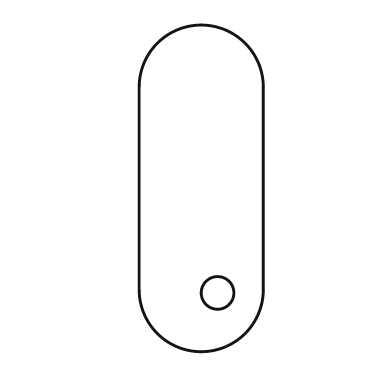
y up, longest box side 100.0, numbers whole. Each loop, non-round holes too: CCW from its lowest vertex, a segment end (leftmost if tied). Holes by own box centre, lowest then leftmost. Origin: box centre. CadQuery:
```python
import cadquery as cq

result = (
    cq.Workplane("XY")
    .moveTo(-19.0, -31.0)
    .threePointArc((0.0, -50.0), (19.0, -31.0))
    .lineTo(19.0, 31.0)
    .threePointArc((0.0, 50.0), (-19.0, 31.0))
    .close()
    .moveTo(5.0, -32.0)
    .circle(5.0)
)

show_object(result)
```